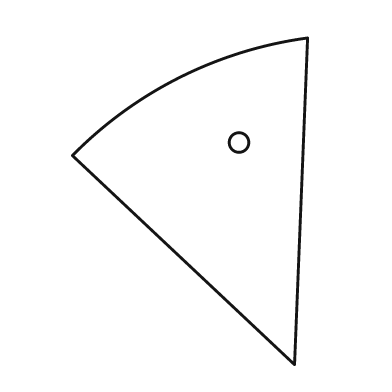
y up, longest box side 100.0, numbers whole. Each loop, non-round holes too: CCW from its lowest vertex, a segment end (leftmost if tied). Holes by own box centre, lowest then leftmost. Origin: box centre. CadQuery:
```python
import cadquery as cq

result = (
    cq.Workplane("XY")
    .moveTo(32.0, -50.0)
    .lineTo(36.0, 50.0)
    .threePointArc((-3.0, 38.0), (-36.0, 14.0))
    .close()
    .moveTo(15.0, 18.0)
    .circle(3.0)
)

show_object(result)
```